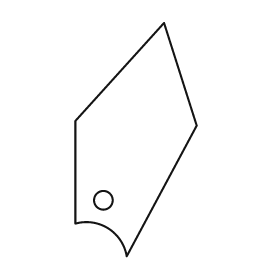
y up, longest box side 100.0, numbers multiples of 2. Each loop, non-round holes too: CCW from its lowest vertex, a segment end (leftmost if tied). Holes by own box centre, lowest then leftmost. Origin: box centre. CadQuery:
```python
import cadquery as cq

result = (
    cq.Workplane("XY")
    .moveTo(-4.0, -50.0)
    .lineTo(26.0, 6.0)
    .lineTo(12.0, 50.0)
    .lineTo(-26.0, 8.0)
    .lineTo(-26.0, -36.0)
    .threePointArc((-12.0, -38.0), (-4.0, -50.0))
    .close()
    .moveTo(-14.0, -26.0)
    .circle(4.0)
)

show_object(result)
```